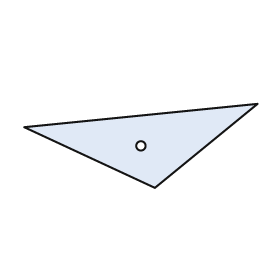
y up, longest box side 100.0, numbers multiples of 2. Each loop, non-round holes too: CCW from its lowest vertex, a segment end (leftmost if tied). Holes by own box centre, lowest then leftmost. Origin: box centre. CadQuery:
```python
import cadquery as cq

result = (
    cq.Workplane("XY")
    .moveTo(6.0, -18.0)
    .lineTo(50.0, 18.0)
    .lineTo(-50.0, 8.0)
    .close()
    .moveTo(0.0, 0.0)
    .circle(2.0)
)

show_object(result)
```